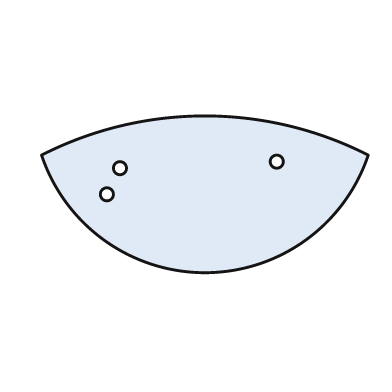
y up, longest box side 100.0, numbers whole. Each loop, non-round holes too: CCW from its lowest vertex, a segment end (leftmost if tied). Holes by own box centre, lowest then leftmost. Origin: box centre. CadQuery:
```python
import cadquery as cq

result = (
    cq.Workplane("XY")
    .moveTo(-50.0, 12.0)
    .threePointArc((0.0, -24.0), (50.0, 12.0))
    .threePointArc((0.0, 24.0), (-50.0, 12.0))
    .close()
    .moveTo(-30.0, 0.0)
    .circle(2.0)
    .moveTo(-26.0, 8.0)
    .circle(2.0)
    .moveTo(22.0, 10.0)
    .circle(2.0)
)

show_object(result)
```